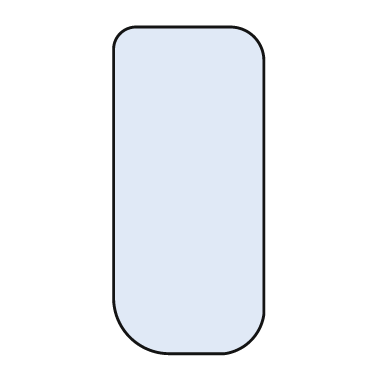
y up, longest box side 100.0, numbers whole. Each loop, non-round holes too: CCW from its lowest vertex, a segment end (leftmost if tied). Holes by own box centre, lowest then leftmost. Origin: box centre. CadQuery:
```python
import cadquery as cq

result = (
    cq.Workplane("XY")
    .moveTo(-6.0, -50.0)
    .lineTo(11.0, -50.0)
    .threePointArc((19.0, -46.0), (23.0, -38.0))
    .lineTo(23.0, 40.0)
    .threePointArc((20.0, 47.0), (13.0, 50.0))
    .lineTo(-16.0, 50.0)
    .threePointArc((-21.0, 48.0), (-23.0, 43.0))
    .lineTo(-23.0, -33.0)
    .threePointArc((-18.0, -45.0), (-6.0, -50.0))
    .close()
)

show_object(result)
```